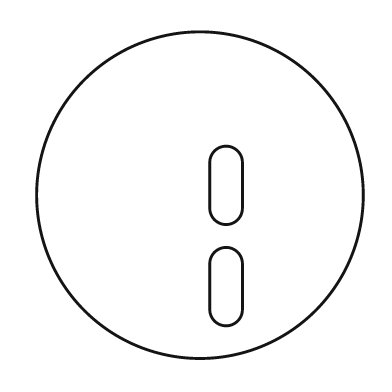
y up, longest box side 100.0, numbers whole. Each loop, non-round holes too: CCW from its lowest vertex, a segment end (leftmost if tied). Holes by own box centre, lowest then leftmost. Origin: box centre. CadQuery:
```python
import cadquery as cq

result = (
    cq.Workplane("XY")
    .moveTo(0.0, 0.0)
    .circle(50.0)
    .moveTo(3.0, -35.0)
    .threePointArc((8.0, -40.0), (13.0, -35.0))
    .lineTo(13.0, -21.0)
    .threePointArc((8.0, -16.0), (3.0, -21.0))
    .close()
    .moveTo(3.0, -4.0)
    .threePointArc((8.0, -9.0), (13.0, -4.0))
    .lineTo(13.0, 10.0)
    .threePointArc((8.0, 15.0), (3.0, 10.0))
    .close()
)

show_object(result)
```